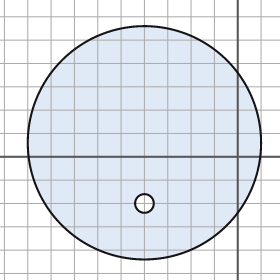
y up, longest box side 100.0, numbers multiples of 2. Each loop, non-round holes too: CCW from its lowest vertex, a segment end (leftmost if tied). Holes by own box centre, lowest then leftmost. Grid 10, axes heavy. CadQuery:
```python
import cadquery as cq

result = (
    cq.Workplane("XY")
    .moveTo(-40.0, 6.0)
    .circle(50.0)
    .moveTo(-40.0, -20.0)
    .circle(4.0)
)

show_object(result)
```